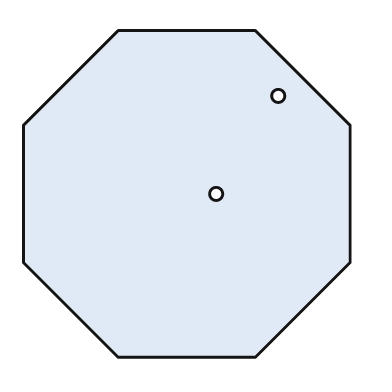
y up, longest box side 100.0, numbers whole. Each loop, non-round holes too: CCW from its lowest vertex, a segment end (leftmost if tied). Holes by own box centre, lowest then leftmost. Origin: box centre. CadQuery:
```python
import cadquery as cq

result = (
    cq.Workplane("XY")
    .moveTo(-21.0, -50.0)
    .lineTo(21.0, -50.0)
    .lineTo(50.0, -21.0)
    .lineTo(50.0, 21.0)
    .lineTo(21.0, 50.0)
    .lineTo(-21.0, 50.0)
    .lineTo(-50.0, 21.0)
    .lineTo(-50.0, -21.0)
    .close()
    .moveTo(9.0, 0.0)
    .circle(2.0)
    .moveTo(28.0, 30.0)
    .circle(2.0)
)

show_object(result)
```